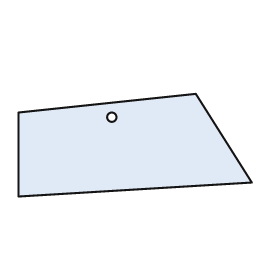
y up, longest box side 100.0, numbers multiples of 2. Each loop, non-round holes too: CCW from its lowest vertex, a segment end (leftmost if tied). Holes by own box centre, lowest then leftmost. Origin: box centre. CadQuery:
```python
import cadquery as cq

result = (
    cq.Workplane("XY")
    .moveTo(-50.0, -22.0)
    .lineTo(50.0, -16.0)
    .lineTo(26.0, 22.0)
    .lineTo(-50.0, 14.0)
    .close()
    .moveTo(-10.0, 12.0)
    .circle(2.0)
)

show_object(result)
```